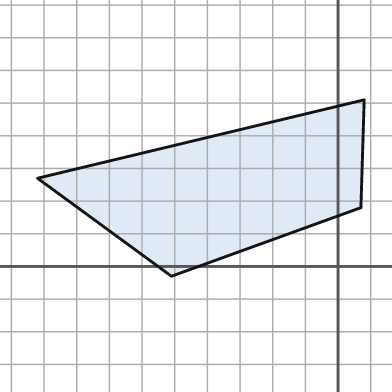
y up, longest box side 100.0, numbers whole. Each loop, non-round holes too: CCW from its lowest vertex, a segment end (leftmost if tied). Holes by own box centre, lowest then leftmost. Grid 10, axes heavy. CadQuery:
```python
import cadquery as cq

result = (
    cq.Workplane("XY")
    .moveTo(-51.0, -3.0)
    .lineTo(7.0, 18.0)
    .lineTo(8.0, 51.0)
    .lineTo(-92.0, 27.0)
    .close()
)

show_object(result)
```